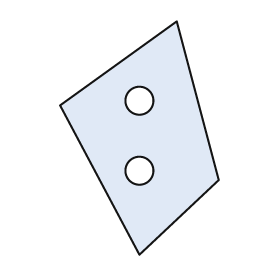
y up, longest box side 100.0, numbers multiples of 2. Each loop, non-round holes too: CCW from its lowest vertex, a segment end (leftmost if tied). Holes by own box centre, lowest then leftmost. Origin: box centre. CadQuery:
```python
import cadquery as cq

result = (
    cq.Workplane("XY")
    .moveTo(0.0, -50.0)
    .lineTo(34.0, -18.0)
    .lineTo(16.0, 50.0)
    .lineTo(-34.0, 14.0)
    .close()
    .moveTo(0.0, -14.0)
    .circle(6.0)
    .moveTo(0.0, 16.0)
    .circle(6.0)
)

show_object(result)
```